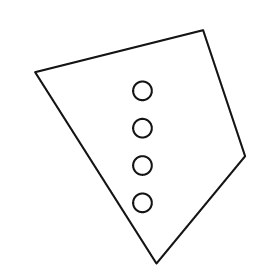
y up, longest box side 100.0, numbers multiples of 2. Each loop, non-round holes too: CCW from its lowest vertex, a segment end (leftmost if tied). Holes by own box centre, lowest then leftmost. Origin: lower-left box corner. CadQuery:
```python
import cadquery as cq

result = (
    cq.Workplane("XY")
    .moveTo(52.0, 0.0)
    .lineTo(90.0, 46.0)
    .lineTo(72.0, 100.0)
    .lineTo(0.0, 82.0)
    .close()
    .moveTo(46.0, 26.0)
    .circle(4.0)
    .moveTo(46.0, 42.0)
    .circle(4.0)
    .moveTo(46.0, 58.0)
    .circle(4.0)
    .moveTo(46.0, 74.0)
    .circle(4.0)
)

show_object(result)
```